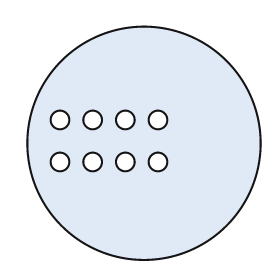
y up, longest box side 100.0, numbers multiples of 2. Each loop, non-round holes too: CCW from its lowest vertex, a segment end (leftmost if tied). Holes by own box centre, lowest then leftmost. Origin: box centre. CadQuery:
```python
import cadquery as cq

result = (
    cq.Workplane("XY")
    .moveTo(0.0, 0.0)
    .circle(50.0)
    .moveTo(-36.0, -8.0)
    .circle(4.0)
    .moveTo(-22.0, -8.0)
    .circle(4.0)
    .moveTo(-8.0, -8.0)
    .circle(4.0)
    .moveTo(6.0, -8.0)
    .circle(4.0)
    .moveTo(-36.0, 10.0)
    .circle(4.0)
    .moveTo(-22.0, 10.0)
    .circle(4.0)
    .moveTo(-8.0, 10.0)
    .circle(4.0)
    .moveTo(6.0, 10.0)
    .circle(4.0)
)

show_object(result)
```